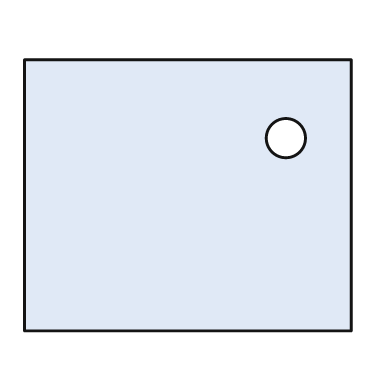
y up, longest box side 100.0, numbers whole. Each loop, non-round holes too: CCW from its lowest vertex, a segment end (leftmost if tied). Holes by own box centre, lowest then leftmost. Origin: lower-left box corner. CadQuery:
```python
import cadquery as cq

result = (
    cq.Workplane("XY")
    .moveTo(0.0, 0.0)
    .lineTo(100.0, 0.0)
    .lineTo(100.0, 83.0)
    .lineTo(0.0, 83.0)
    .close()
    .moveTo(80.0, 59.0)
    .circle(6.0)
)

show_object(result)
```